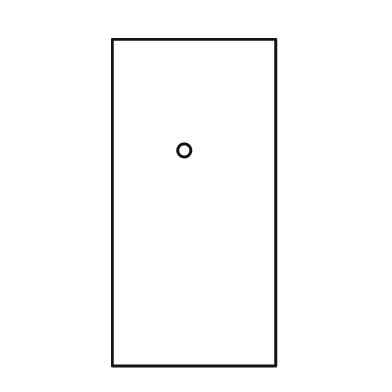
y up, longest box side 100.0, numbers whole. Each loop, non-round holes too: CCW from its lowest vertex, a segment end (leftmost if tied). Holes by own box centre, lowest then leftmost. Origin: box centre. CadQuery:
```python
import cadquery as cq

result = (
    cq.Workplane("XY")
    .moveTo(-25.0, -50.0)
    .lineTo(25.0, -50.0)
    .lineTo(25.0, 50.0)
    .lineTo(-25.0, 50.0)
    .close()
    .moveTo(-3.0, 16.0)
    .circle(2.0)
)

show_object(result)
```